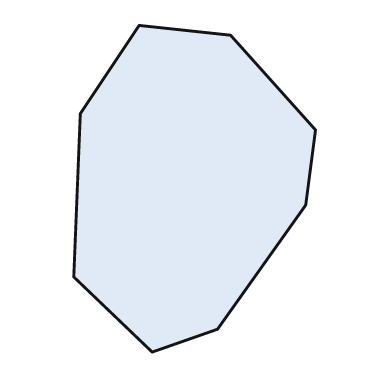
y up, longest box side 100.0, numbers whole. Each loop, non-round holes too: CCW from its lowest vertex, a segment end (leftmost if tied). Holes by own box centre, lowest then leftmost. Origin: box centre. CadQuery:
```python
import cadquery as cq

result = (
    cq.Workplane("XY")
    .moveTo(-13.0, -50.0)
    .lineTo(7.0, -43.0)
    .lineTo(34.0, -5.0)
    .lineTo(37.0, 18.0)
    .lineTo(11.0, 47.0)
    .lineTo(-17.0, 50.0)
    .lineTo(-35.0, 23.0)
    .lineTo(-37.0, -27.0)
    .close()
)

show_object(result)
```